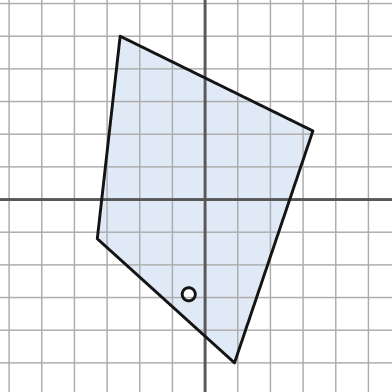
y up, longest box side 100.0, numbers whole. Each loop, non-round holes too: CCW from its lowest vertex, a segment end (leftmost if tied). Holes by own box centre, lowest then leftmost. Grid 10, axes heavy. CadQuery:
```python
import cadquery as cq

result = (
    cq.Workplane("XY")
    .moveTo(9.0, -50.0)
    .lineTo(33.0, 21.0)
    .lineTo(-26.0, 50.0)
    .lineTo(-33.0, -12.0)
    .close()
    .moveTo(-5.0, -29.0)
    .circle(2.0)
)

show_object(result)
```